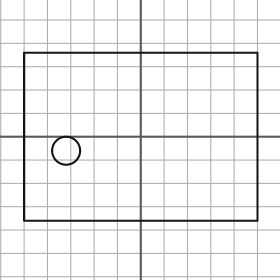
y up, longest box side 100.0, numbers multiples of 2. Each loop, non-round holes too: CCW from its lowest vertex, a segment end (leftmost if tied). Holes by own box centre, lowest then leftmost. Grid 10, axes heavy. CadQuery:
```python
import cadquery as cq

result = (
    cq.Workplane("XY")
    .moveTo(-50.0, -36.0)
    .lineTo(50.0, -36.0)
    .lineTo(50.0, 36.0)
    .lineTo(-50.0, 36.0)
    .close()
    .moveTo(-32.0, -6.0)
    .circle(6.0)
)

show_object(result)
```